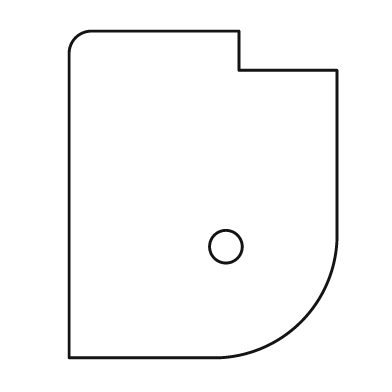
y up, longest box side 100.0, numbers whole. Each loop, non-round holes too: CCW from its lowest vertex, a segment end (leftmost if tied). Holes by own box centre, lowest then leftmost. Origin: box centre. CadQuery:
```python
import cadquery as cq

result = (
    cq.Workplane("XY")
    .moveTo(-41.0, -50.0)
    .lineTo(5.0, -50.0)
    .threePointArc((30.0, -39.0), (41.0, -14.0))
    .lineTo(41.0, 38.0)
    .lineTo(11.0, 38.0)
    .lineTo(11.0, 50.0)
    .lineTo(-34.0, 50.0)
    .threePointArc((-39.0, 48.0), (-41.0, 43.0))
    .close()
    .moveTo(7.0, -16.0)
    .circle(5.0)
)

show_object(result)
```